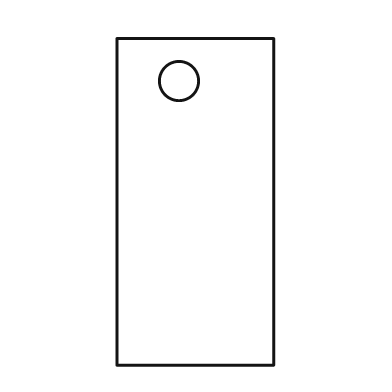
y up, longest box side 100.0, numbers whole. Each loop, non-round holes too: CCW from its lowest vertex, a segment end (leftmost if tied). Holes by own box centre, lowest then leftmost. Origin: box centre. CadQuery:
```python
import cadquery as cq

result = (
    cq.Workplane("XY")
    .moveTo(-24.0, -50.0)
    .lineTo(24.0, -50.0)
    .lineTo(24.0, 50.0)
    .lineTo(-24.0, 50.0)
    .close()
    .moveTo(-5.0, 37.0)
    .circle(6.0)
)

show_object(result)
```